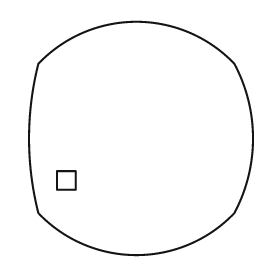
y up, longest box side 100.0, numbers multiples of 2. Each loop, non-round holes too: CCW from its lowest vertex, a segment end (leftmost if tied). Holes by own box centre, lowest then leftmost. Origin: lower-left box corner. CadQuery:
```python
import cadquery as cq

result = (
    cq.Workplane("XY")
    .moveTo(4.0, 18.0)
    .threePointArc((46.0, 0.0), (88.0, 18.0))
    .threePointArc((96.0, 50.0), (88.0, 82.0))
    .threePointArc((46.0, 100.0), (4.0, 82.0))
    .threePointArc((0.0, 50.0), (4.0, 18.0))
    .close()
    .moveTo(12.0, 28.0)
    .lineTo(20.0, 28.0)
    .lineTo(20.0, 36.0)
    .lineTo(12.0, 36.0)
    .close()
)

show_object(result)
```